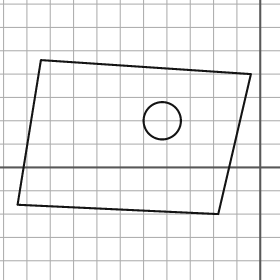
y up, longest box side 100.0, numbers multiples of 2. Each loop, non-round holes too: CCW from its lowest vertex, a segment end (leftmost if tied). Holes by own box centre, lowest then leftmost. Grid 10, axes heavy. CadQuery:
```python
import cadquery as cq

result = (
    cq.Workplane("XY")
    .moveTo(-18.0, -20.0)
    .lineTo(-4.0, 40.0)
    .lineTo(-94.0, 46.0)
    .lineTo(-104.0, -16.0)
    .close()
    .moveTo(-42.0, 20.0)
    .circle(8.0)
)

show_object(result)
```